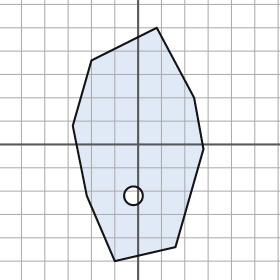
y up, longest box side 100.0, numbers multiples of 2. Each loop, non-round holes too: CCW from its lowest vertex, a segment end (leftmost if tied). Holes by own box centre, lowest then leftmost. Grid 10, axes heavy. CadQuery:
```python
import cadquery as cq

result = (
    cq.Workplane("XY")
    .moveTo(-10.0, -50.0)
    .lineTo(16.0, -44.0)
    .lineTo(28.0, -2.0)
    .lineTo(24.0, 20.0)
    .lineTo(8.0, 50.0)
    .lineTo(-20.0, 36.0)
    .lineTo(-28.0, 8.0)
    .lineTo(-22.0, -22.0)
    .close()
    .moveTo(-2.0, -22.0)
    .circle(4.0)
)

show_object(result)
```